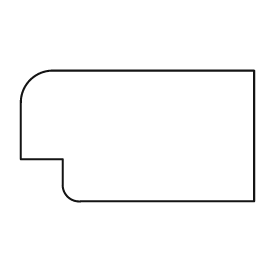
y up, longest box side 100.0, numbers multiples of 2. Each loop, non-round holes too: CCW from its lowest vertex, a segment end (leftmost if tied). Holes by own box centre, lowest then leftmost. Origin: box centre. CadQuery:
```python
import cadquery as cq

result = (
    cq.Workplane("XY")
    .moveTo(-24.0, -28.0)
    .lineTo(50.0, -28.0)
    .lineTo(50.0, 28.0)
    .lineTo(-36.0, 28.0)
    .threePointArc((-46.0, 24.0), (-50.0, 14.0))
    .lineTo(-50.0, -10.0)
    .lineTo(-32.0, -10.0)
    .lineTo(-32.0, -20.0)
    .threePointArc((-30.0, -26.0), (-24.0, -28.0))
    .close()
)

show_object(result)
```